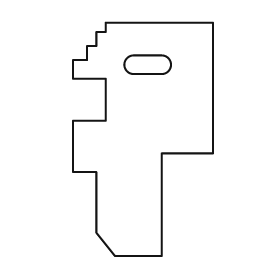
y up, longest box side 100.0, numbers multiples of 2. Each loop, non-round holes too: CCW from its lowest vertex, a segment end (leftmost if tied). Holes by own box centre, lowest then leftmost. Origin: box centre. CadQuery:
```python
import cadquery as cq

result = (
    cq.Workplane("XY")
    .moveTo(-12.0, -50.0)
    .lineTo(8.0, -50.0)
    .lineTo(8.0, -6.0)
    .lineTo(30.0, -6.0)
    .lineTo(30.0, 50.0)
    .lineTo(-16.0, 50.0)
    .lineTo(-16.0, 46.0)
    .lineTo(-20.0, 46.0)
    .lineTo(-20.0, 40.0)
    .lineTo(-24.0, 40.0)
    .lineTo(-24.0, 34.0)
    .lineTo(-30.0, 34.0)
    .lineTo(-30.0, 26.0)
    .lineTo(-16.0, 26.0)
    .lineTo(-16.0, 8.0)
    .lineTo(-30.0, 8.0)
    .lineTo(-30.0, -14.0)
    .lineTo(-20.0, -14.0)
    .lineTo(-20.0, -40.0)
    .close()
    .moveTo(-4.0, 28.0)
    .lineTo(8.0, 28.0)
    .threePointArc((12.0, 32.0), (8.0, 36.0))
    .lineTo(-4.0, 36.0)
    .threePointArc((-8.0, 32.0), (-4.0, 28.0))
    .close()
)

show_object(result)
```